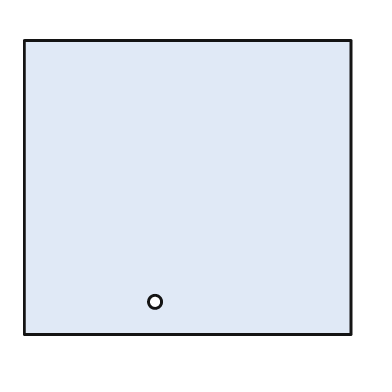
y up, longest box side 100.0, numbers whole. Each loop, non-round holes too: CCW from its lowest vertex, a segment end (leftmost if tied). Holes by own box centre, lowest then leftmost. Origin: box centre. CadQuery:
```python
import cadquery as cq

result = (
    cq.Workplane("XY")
    .moveTo(-50.0, -45.0)
    .lineTo(50.0, -45.0)
    .lineTo(50.0, 45.0)
    .lineTo(-50.0, 45.0)
    .close()
    .moveTo(-10.0, -35.0)
    .circle(2.0)
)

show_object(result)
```